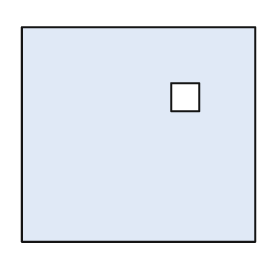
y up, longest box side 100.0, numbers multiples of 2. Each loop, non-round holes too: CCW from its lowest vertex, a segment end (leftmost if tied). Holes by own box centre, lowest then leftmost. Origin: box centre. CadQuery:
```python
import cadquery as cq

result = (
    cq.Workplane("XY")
    .moveTo(-50.0, -46.0)
    .lineTo(50.0, -46.0)
    .lineTo(50.0, 46.0)
    .lineTo(-50.0, 46.0)
    .close()
    .moveTo(14.0, 10.0)
    .lineTo(26.0, 10.0)
    .lineTo(26.0, 22.0)
    .lineTo(14.0, 22.0)
    .close()
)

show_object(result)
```